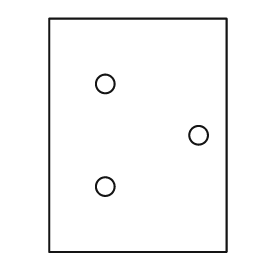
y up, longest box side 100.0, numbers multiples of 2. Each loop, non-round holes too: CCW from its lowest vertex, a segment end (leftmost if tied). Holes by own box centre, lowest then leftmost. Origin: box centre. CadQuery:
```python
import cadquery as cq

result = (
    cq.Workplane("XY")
    .moveTo(-38.0, -50.0)
    .lineTo(38.0, -50.0)
    .lineTo(38.0, 50.0)
    .lineTo(-38.0, 50.0)
    .close()
    .moveTo(-14.0, -22.0)
    .circle(4.0)
    .moveTo(26.0, 0.0)
    .circle(4.0)
    .moveTo(-14.0, 22.0)
    .circle(4.0)
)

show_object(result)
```